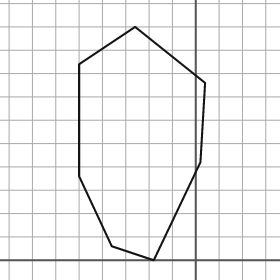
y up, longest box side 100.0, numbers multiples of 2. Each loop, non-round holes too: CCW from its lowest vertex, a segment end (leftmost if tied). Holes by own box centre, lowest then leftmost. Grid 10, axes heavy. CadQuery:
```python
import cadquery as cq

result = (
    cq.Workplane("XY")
    .moveTo(-18.0, 0.0)
    .lineTo(2.0, 42.0)
    .lineTo(4.0, 76.0)
    .lineTo(-26.0, 100.0)
    .lineTo(-50.0, 84.0)
    .lineTo(-50.0, 36.0)
    .lineTo(-36.0, 6.0)
    .close()
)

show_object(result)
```